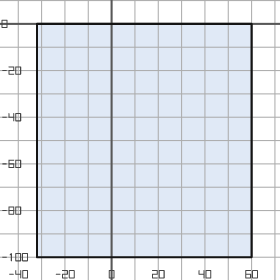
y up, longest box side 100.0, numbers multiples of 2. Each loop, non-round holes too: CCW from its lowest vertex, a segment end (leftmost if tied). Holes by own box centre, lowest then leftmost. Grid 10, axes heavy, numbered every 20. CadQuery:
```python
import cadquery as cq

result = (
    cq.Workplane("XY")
    .moveTo(-32.0, -100.0)
    .lineTo(60.0, -100.0)
    .lineTo(60.0, 0.0)
    .lineTo(-32.0, 0.0)
    .close()
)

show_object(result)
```